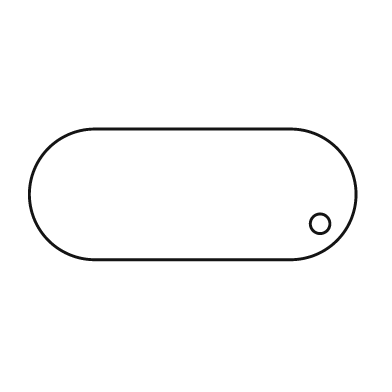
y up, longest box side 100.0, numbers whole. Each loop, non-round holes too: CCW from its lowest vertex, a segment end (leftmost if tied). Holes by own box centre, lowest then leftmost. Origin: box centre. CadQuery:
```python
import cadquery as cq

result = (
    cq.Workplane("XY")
    .moveTo(-30.0, -20.0)
    .lineTo(30.0, -20.0)
    .threePointArc((50.0, 0.0), (30.0, 20.0))
    .lineTo(-30.0, 20.0)
    .threePointArc((-50.0, 0.0), (-30.0, -20.0))
    .close()
    .moveTo(39.0, -9.0)
    .circle(3.0)
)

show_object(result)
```